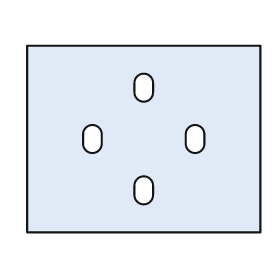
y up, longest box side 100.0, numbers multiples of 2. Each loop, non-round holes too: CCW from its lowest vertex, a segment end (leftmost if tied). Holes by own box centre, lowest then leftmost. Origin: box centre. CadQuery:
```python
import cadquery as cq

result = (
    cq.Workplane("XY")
    .moveTo(-50.0, -40.0)
    .lineTo(50.0, -40.0)
    .lineTo(50.0, 40.0)
    .lineTo(-50.0, 40.0)
    .close()
    .moveTo(-4.0, -24.0)
    .threePointArc((0.0, -28.0), (4.0, -24.0))
    .lineTo(4.0, -20.0)
    .threePointArc((0.0, -16.0), (-4.0, -20.0))
    .close()
    .moveTo(-26.0, -2.0)
    .threePointArc((-22.0, -6.0), (-18.0, -2.0))
    .lineTo(-18.0, 2.0)
    .threePointArc((-22.0, 6.0), (-26.0, 2.0))
    .close()
    .moveTo(18.0, -2.0)
    .threePointArc((22.0, -6.0), (26.0, -2.0))
    .lineTo(26.0, 2.0)
    .threePointArc((22.0, 6.0), (18.0, 2.0))
    .close()
    .moveTo(-4.0, 20.0)
    .threePointArc((0.0, 16.0), (4.0, 20.0))
    .lineTo(4.0, 24.0)
    .threePointArc((0.0, 28.0), (-4.0, 24.0))
    .close()
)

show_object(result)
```